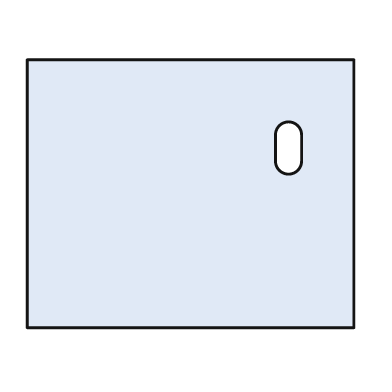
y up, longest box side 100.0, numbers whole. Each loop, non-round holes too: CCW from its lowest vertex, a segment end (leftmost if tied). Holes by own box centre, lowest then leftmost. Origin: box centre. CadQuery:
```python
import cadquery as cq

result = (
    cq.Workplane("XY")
    .moveTo(-50.0, -41.0)
    .lineTo(50.0, -41.0)
    .lineTo(50.0, 41.0)
    .lineTo(-50.0, 41.0)
    .close()
    .moveTo(26.0, 10.0)
    .threePointArc((30.0, 6.0), (34.0, 10.0))
    .lineTo(34.0, 18.0)
    .threePointArc((30.0, 22.0), (26.0, 18.0))
    .close()
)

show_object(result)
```